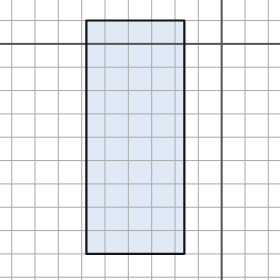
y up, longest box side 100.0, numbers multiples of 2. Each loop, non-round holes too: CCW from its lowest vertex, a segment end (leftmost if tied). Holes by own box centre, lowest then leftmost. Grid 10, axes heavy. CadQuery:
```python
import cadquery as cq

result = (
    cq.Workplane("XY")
    .moveTo(-58.0, -90.0)
    .lineTo(-16.0, -90.0)
    .lineTo(-16.0, 10.0)
    .lineTo(-58.0, 10.0)
    .close()
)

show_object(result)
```